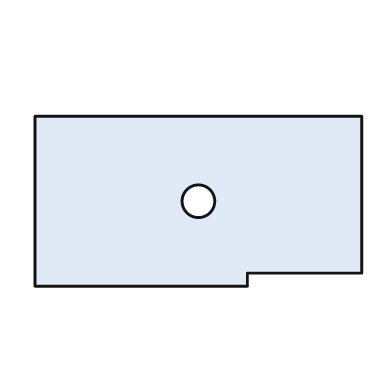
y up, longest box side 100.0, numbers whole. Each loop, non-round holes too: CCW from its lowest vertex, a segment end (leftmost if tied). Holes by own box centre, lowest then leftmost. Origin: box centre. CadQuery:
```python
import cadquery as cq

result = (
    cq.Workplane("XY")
    .moveTo(-50.0, -26.0)
    .lineTo(15.0, -26.0)
    .lineTo(15.0, -22.0)
    .lineTo(50.0, -22.0)
    .lineTo(50.0, 26.0)
    .lineTo(-50.0, 26.0)
    .close()
    .moveTo(0.0, 0.0)
    .circle(5.0)
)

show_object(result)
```